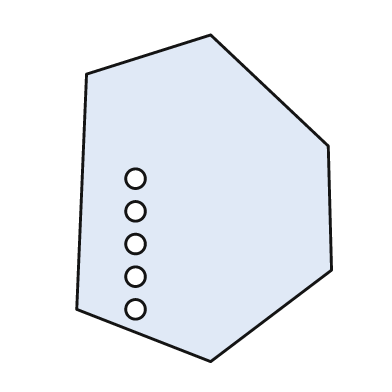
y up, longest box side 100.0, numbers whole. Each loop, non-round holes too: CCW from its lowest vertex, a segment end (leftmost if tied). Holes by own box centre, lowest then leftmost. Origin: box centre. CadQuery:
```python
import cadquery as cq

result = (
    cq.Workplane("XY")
    .moveTo(2.0, -50.0)
    .lineTo(39.0, -22.0)
    .lineTo(38.0, 16.0)
    .lineTo(2.0, 50.0)
    .lineTo(-36.0, 38.0)
    .lineTo(-39.0, -34.0)
    .close()
    .moveTo(-21.0, -34.0)
    .circle(3.0)
    .moveTo(-21.0, -24.0)
    .circle(3.0)
    .moveTo(-21.0, -14.0)
    .circle(3.0)
    .moveTo(-21.0, -4.0)
    .circle(3.0)
    .moveTo(-21.0, 6.0)
    .circle(3.0)
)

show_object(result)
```